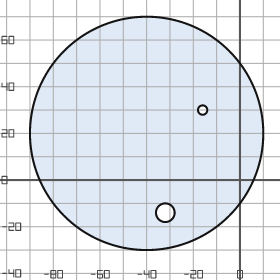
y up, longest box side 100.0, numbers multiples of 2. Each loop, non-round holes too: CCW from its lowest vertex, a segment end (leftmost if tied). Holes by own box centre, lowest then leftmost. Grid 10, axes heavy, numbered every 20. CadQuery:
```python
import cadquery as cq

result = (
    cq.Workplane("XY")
    .moveTo(-40.0, 20.0)
    .circle(50.0)
    .moveTo(-32.0, -14.0)
    .circle(4.0)
    .moveTo(-16.0, 30.0)
    .circle(2.0)
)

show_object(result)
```